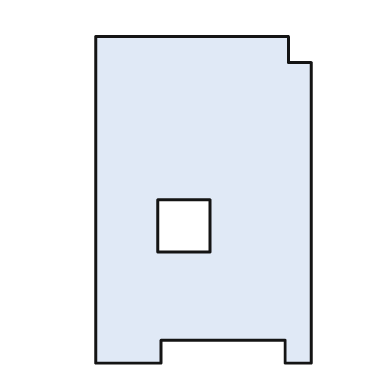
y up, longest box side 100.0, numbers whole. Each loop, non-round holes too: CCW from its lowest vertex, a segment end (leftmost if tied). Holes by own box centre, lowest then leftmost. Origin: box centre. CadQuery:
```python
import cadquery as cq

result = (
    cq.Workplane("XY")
    .moveTo(-33.0, -50.0)
    .lineTo(-13.0, -50.0)
    .lineTo(-13.0, -43.0)
    .lineTo(25.0, -43.0)
    .lineTo(25.0, -50.0)
    .lineTo(33.0, -50.0)
    .lineTo(33.0, 42.0)
    .lineTo(26.0, 42.0)
    .lineTo(26.0, 50.0)
    .lineTo(-33.0, 50.0)
    .close()
    .moveTo(-14.0, -16.0)
    .lineTo(2.0, -16.0)
    .lineTo(2.0, 0.0)
    .lineTo(-14.0, 0.0)
    .close()
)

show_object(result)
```